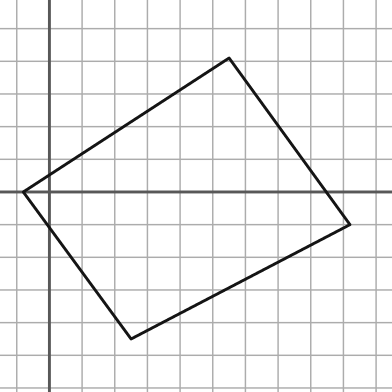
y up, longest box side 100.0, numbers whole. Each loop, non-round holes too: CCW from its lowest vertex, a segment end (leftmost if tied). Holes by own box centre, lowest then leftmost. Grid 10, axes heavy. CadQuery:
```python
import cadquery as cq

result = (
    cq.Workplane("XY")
    .moveTo(25.0, -45.0)
    .lineTo(92.0, -10.0)
    .lineTo(55.0, 41.0)
    .lineTo(-8.0, 0.0)
    .close()
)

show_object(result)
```